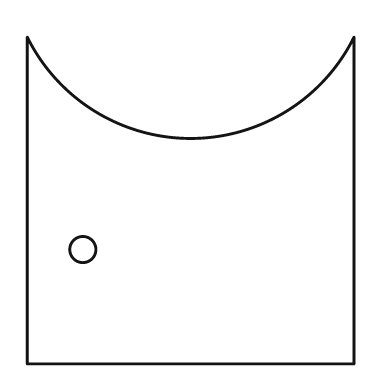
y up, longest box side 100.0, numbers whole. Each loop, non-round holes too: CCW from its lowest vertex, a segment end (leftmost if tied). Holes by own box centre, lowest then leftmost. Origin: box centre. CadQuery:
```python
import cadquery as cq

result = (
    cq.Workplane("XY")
    .moveTo(-50.0, -50.0)
    .lineTo(50.0, -50.0)
    .lineTo(50.0, 50.0)
    .threePointArc((0.0, 19.0), (-50.0, 50.0))
    .close()
    .moveTo(-33.0, -15.0)
    .circle(4.0)
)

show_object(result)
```